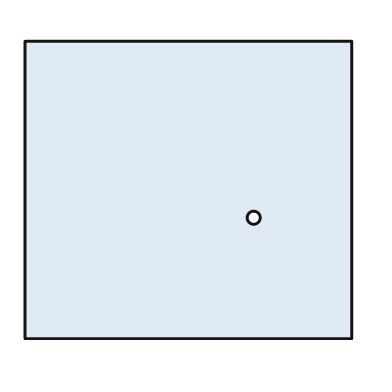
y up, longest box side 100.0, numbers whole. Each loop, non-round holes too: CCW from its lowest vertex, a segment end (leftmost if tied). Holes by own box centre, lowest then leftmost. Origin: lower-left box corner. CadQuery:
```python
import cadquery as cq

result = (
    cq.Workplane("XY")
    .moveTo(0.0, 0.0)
    .lineTo(100.0, 0.0)
    .lineTo(100.0, 91.0)
    .lineTo(0.0, 91.0)
    .close()
    .moveTo(70.0, 37.0)
    .circle(2.0)
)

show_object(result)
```